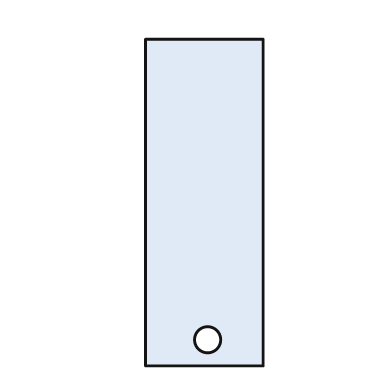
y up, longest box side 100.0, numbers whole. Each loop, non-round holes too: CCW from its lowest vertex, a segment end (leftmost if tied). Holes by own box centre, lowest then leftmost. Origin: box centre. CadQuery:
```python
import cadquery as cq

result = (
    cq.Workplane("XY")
    .moveTo(-18.0, -50.0)
    .lineTo(18.0, -50.0)
    .lineTo(18.0, 50.0)
    .lineTo(-18.0, 50.0)
    .close()
    .moveTo(1.0, -42.0)
    .circle(4.0)
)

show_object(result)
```